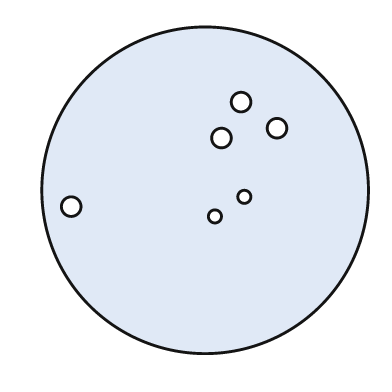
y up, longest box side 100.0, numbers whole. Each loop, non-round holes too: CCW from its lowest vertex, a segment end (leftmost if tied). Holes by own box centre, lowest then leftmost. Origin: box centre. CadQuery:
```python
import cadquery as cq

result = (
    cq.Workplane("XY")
    .moveTo(0.0, 0.0)
    .circle(50.0)
    .moveTo(3.0, -8.0)
    .circle(2.0)
    .moveTo(-41.0, -5.0)
    .circle(3.0)
    .moveTo(12.0, -2.0)
    .circle(2.0)
    .moveTo(5.0, 16.0)
    .circle(3.0)
    .moveTo(22.0, 19.0)
    .circle(3.0)
    .moveTo(11.0, 27.0)
    .circle(3.0)
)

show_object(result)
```